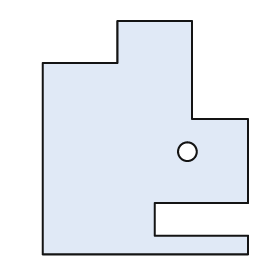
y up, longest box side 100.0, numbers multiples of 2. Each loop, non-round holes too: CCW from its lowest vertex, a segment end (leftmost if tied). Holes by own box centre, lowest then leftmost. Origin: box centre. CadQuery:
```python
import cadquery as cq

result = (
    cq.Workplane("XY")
    .moveTo(-44.0, -50.0)
    .lineTo(44.0, -50.0)
    .lineTo(44.0, -42.0)
    .lineTo(4.0, -42.0)
    .lineTo(4.0, -28.0)
    .lineTo(44.0, -28.0)
    .lineTo(44.0, 8.0)
    .lineTo(20.0, 8.0)
    .lineTo(20.0, 50.0)
    .lineTo(-12.0, 50.0)
    .lineTo(-12.0, 32.0)
    .lineTo(-44.0, 32.0)
    .close()
    .moveTo(18.0, -6.0)
    .circle(4.0)
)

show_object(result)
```